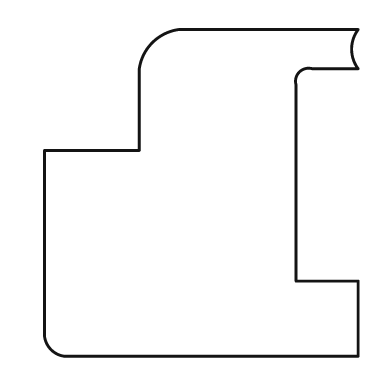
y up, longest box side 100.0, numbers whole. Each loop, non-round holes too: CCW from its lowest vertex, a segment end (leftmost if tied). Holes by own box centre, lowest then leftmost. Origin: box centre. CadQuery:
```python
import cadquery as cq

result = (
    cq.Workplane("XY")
    .moveTo(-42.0, -50.0)
    .lineTo(48.0, -50.0)
    .lineTo(48.0, -27.0)
    .lineTo(29.0, -27.0)
    .lineTo(29.0, 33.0)
    .threePointArc((30.0, 37.0), (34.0, 38.0))
    .lineTo(48.0, 38.0)
    .threePointArc((46.0, 44.0), (48.0, 50.0))
    .lineTo(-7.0, 50.0)
    .threePointArc((-15.0, 46.0), (-19.0, 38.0))
    .lineTo(-19.0, 13.0)
    .lineTo(-48.0, 13.0)
    .lineTo(-48.0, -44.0)
    .threePointArc((-46.0, -48.0), (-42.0, -50.0))
    .close()
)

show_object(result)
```